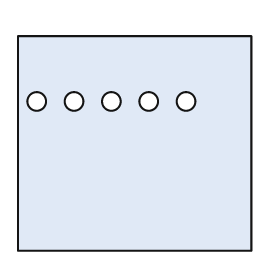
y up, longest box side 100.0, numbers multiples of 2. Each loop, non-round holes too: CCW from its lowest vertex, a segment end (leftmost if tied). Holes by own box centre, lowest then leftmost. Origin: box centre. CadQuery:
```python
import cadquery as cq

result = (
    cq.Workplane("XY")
    .moveTo(-50.0, -46.0)
    .lineTo(50.0, -46.0)
    .lineTo(50.0, 46.0)
    .lineTo(-50.0, 46.0)
    .close()
    .moveTo(-42.0, 18.0)
    .circle(4.0)
    .moveTo(-26.0, 18.0)
    .circle(4.0)
    .moveTo(-10.0, 18.0)
    .circle(4.0)
    .moveTo(6.0, 18.0)
    .circle(4.0)
    .moveTo(22.0, 18.0)
    .circle(4.0)
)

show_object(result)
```